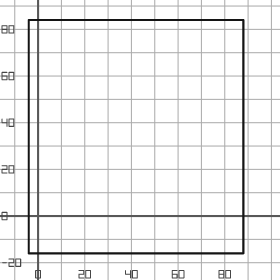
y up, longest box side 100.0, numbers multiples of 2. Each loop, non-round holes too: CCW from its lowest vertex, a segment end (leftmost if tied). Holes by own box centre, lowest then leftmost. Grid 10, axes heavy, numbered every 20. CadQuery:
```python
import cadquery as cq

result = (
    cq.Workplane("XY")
    .moveTo(-4.0, -16.0)
    .lineTo(88.0, -16.0)
    .lineTo(88.0, 84.0)
    .lineTo(-4.0, 84.0)
    .close()
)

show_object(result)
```